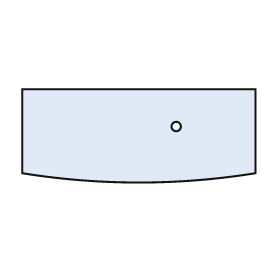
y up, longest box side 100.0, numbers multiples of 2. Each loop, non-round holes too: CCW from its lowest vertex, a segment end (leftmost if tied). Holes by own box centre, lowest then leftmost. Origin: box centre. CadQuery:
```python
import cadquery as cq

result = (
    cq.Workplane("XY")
    .moveTo(-50.0, -16.0)
    .threePointArc((0.0, -20.0), (50.0, -16.0))
    .lineTo(50.0, 20.0)
    .lineTo(-50.0, 20.0)
    .close()
    .moveTo(16.0, 4.0)
    .circle(2.0)
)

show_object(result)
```